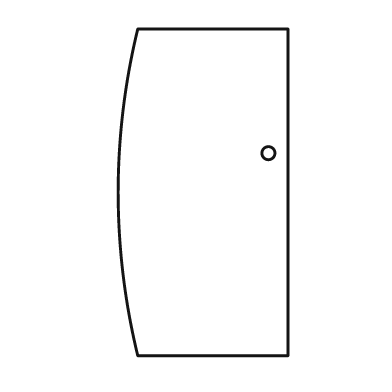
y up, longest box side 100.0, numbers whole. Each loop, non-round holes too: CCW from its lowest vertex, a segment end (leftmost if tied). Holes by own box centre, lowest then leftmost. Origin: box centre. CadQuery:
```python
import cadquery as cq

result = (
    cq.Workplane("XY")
    .moveTo(-20.0, -50.0)
    .lineTo(26.0, -50.0)
    .lineTo(26.0, 50.0)
    .lineTo(-20.0, 50.0)
    .threePointArc((-26.0, 0.0), (-20.0, -50.0))
    .close()
    .moveTo(20.0, 12.0)
    .circle(2.0)
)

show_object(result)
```